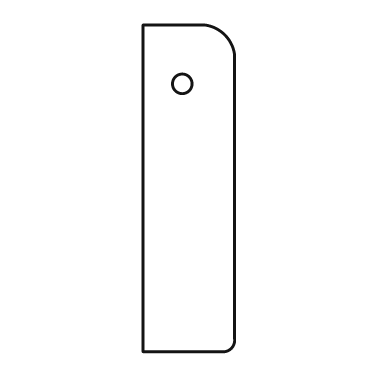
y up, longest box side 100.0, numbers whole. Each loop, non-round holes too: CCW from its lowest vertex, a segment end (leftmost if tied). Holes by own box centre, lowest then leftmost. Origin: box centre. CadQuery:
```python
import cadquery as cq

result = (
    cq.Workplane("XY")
    .moveTo(-14.0, -50.0)
    .lineTo(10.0, -50.0)
    .threePointArc((13.0, -49.0), (14.0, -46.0))
    .lineTo(14.0, 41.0)
    .threePointArc((11.0, 47.0), (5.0, 50.0))
    .lineTo(-14.0, 50.0)
    .close()
    .moveTo(-2.0, 32.0)
    .circle(3.0)
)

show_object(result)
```